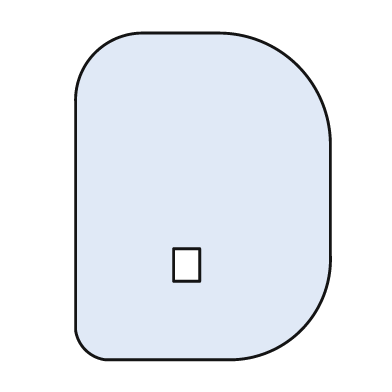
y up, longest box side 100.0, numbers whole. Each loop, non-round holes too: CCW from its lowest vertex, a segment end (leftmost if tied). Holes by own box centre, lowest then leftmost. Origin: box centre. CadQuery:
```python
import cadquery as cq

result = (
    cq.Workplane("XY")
    .moveTo(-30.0, -50.0)
    .lineTo(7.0, -50.0)
    .threePointArc((30.0, -41.0), (39.0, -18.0))
    .lineTo(39.0, 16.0)
    .threePointArc((29.0, 40.0), (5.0, 50.0))
    .lineTo(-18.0, 50.0)
    .threePointArc((-33.0, 44.0), (-39.0, 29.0))
    .lineTo(-39.0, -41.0)
    .threePointArc((-36.0, -47.0), (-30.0, -50.0))
    .close()
    .moveTo(-9.0, -26.0)
    .lineTo(-1.0, -26.0)
    .lineTo(-1.0, -16.0)
    .lineTo(-9.0, -16.0)
    .close()
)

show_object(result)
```